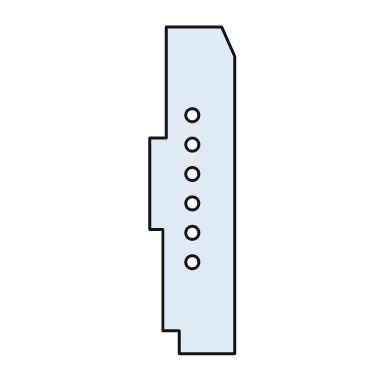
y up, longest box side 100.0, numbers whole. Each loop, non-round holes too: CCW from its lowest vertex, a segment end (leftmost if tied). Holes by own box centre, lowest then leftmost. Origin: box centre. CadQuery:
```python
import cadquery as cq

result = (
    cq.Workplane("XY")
    .moveTo(-4.0, -50.0)
    .lineTo(13.0, -50.0)
    .lineTo(13.0, 41.0)
    .lineTo(9.0, 50.0)
    .lineTo(-8.0, 50.0)
    .lineTo(-8.0, 16.0)
    .lineTo(-13.0, 16.0)
    .lineTo(-13.0, -12.0)
    .lineTo(-9.0, -12.0)
    .lineTo(-9.0, -43.0)
    .lineTo(-4.0, -43.0)
    .close()
    .moveTo(0.0, -22.0)
    .circle(2.0)
    .moveTo(0.0, -13.0)
    .circle(2.0)
    .moveTo(0.0, -4.0)
    .circle(2.0)
    .moveTo(0.0, 5.0)
    .circle(2.0)
    .moveTo(0.0, 14.0)
    .circle(2.0)
    .moveTo(0.0, 23.0)
    .circle(2.0)
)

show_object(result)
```